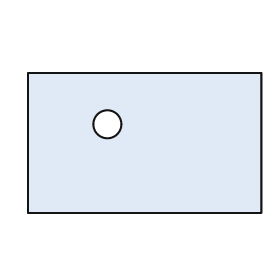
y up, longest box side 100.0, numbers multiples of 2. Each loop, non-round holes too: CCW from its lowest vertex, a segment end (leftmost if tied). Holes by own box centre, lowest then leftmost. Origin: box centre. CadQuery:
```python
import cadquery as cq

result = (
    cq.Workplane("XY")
    .moveTo(-50.0, -30.0)
    .lineTo(50.0, -30.0)
    .lineTo(50.0, 30.0)
    .lineTo(-50.0, 30.0)
    .close()
    .moveTo(-16.0, 8.0)
    .circle(6.0)
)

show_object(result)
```